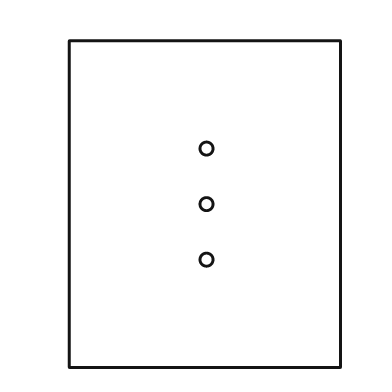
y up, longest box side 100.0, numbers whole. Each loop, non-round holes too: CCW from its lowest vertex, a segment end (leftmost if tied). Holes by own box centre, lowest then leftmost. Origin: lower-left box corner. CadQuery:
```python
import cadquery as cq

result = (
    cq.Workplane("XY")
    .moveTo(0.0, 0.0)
    .lineTo(83.0, 0.0)
    .lineTo(83.0, 100.0)
    .lineTo(0.0, 100.0)
    .close()
    .moveTo(42.0, 33.0)
    .circle(2.0)
    .moveTo(42.0, 50.0)
    .circle(2.0)
    .moveTo(42.0, 67.0)
    .circle(2.0)
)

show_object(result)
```